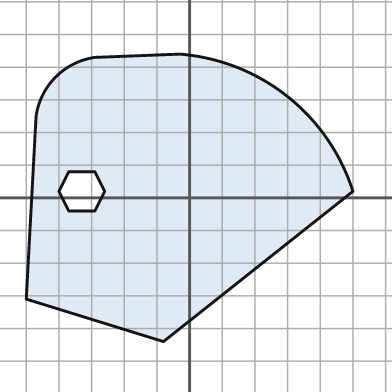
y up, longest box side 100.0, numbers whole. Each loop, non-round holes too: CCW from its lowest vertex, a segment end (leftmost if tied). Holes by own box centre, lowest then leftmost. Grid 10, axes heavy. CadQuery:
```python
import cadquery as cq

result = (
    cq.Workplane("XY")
    .moveTo(-8.0, -44.0)
    .lineTo(50.0, 2.0)
    .threePointArc((30.0, 31.0), (-3.0, 44.0))
    .lineTo(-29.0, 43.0)
    .threePointArc((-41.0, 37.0), (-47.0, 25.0))
    .lineTo(-50.0, -31.0)
    .close()
    .moveTo(-37.0, -4.0)
    .lineTo(-29.0, -4.0)
    .lineTo(-26.0, 2.0)
    .lineTo(-29.0, 8.0)
    .lineTo(-37.0, 8.0)
    .lineTo(-40.0, 2.0)
    .close()
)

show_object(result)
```